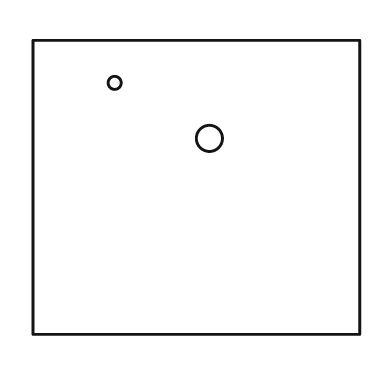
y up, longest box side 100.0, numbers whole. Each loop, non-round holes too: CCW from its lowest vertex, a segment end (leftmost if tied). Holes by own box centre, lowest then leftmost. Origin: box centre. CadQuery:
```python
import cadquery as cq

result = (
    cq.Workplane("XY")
    .moveTo(-50.0, -45.0)
    .lineTo(50.0, -45.0)
    .lineTo(50.0, 45.0)
    .lineTo(-50.0, 45.0)
    .close()
    .moveTo(4.0, 15.0)
    .circle(4.0)
    .moveTo(-25.0, 32.0)
    .circle(2.0)
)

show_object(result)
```